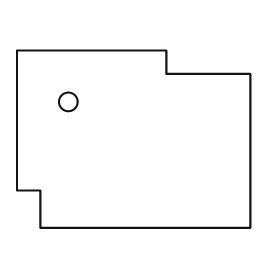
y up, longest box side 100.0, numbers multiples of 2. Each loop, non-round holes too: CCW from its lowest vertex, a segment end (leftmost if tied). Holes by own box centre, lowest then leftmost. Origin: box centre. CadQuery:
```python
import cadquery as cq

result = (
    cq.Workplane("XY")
    .moveTo(-40.0, -38.0)
    .lineTo(50.0, -38.0)
    .lineTo(50.0, 28.0)
    .lineTo(14.0, 28.0)
    .lineTo(14.0, 38.0)
    .lineTo(-50.0, 38.0)
    .lineTo(-50.0, -22.0)
    .lineTo(-40.0, -22.0)
    .close()
    .moveTo(-28.0, 16.0)
    .circle(4.0)
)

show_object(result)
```